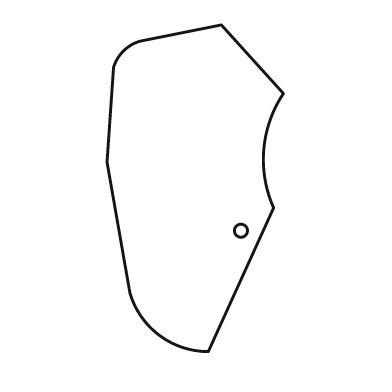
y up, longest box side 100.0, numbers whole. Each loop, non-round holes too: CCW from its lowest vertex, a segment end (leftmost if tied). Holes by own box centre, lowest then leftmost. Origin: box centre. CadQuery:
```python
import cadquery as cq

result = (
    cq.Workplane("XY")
    .moveTo(4.0, -50.0)
    .lineTo(24.0, -6.0)
    .threePointArc((21.0, 12.0), (27.0, 29.0))
    .lineTo(8.0, 50.0)
    .lineTo(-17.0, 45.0)
    .threePointArc((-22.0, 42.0), (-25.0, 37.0))
    .lineTo(-27.0, 8.0)
    .lineTo(-20.0, -32.0)
    .threePointArc((-11.0, -45.0), (4.0, -50.0))
    .close()
    .moveTo(14.0, -13.0)
    .circle(2.0)
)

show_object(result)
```